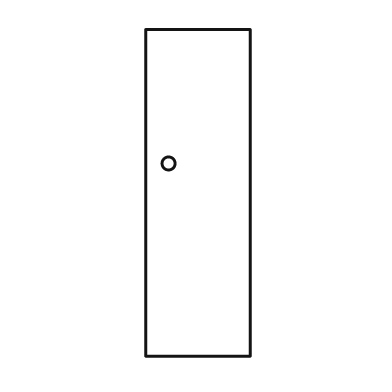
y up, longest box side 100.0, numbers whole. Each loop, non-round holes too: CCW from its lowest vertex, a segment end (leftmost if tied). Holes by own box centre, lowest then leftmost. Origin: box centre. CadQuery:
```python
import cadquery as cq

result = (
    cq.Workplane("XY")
    .moveTo(-16.0, -50.0)
    .lineTo(16.0, -50.0)
    .lineTo(16.0, 50.0)
    .lineTo(-16.0, 50.0)
    .close()
    .moveTo(-9.0, 9.0)
    .circle(2.0)
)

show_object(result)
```